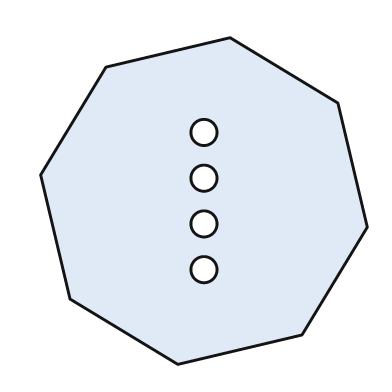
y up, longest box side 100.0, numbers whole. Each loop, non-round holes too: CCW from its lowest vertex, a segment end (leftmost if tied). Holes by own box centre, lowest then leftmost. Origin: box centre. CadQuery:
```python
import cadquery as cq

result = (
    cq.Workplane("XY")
    .moveTo(-8.0, -50.0)
    .lineTo(30.0, -41.0)
    .lineTo(50.0, -8.0)
    .lineTo(41.0, 30.0)
    .lineTo(8.0, 50.0)
    .lineTo(-30.0, 41.0)
    .lineTo(-50.0, 8.0)
    .lineTo(-41.0, -30.0)
    .close()
    .moveTo(0.0, -21.0)
    .circle(4.0)
    .moveTo(0.0, -7.0)
    .circle(4.0)
    .moveTo(0.0, 7.0)
    .circle(4.0)
    .moveTo(0.0, 21.0)
    .circle(4.0)
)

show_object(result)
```